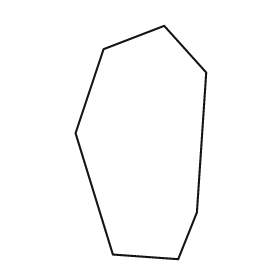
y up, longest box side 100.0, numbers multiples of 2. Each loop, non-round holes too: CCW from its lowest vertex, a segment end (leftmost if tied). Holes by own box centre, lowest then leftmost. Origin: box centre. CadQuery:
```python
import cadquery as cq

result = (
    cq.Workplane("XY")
    .moveTo(16.0, -50.0)
    .lineTo(24.0, -30.0)
    .lineTo(28.0, 30.0)
    .lineTo(10.0, 50.0)
    .lineTo(-16.0, 40.0)
    .lineTo(-28.0, 4.0)
    .lineTo(-12.0, -48.0)
    .close()
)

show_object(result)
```